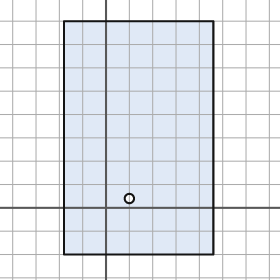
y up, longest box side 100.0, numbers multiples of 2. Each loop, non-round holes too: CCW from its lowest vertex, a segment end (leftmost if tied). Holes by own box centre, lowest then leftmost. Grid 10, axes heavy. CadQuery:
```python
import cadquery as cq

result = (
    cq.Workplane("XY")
    .moveTo(-18.0, -20.0)
    .lineTo(46.0, -20.0)
    .lineTo(46.0, 80.0)
    .lineTo(-18.0, 80.0)
    .close()
    .moveTo(10.0, 4.0)
    .circle(2.0)
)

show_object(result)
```